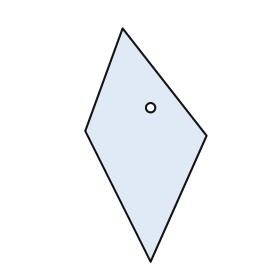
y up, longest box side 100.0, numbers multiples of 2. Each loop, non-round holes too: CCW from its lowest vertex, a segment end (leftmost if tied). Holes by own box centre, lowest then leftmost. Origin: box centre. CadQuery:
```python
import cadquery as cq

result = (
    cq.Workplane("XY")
    .moveTo(2.0, -50.0)
    .lineTo(26.0, 4.0)
    .lineTo(-10.0, 50.0)
    .lineTo(-26.0, 6.0)
    .close()
    .moveTo(2.0, 16.0)
    .circle(2.0)
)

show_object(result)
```